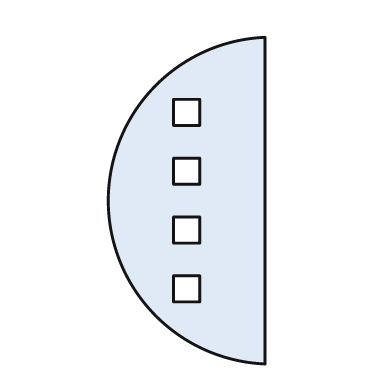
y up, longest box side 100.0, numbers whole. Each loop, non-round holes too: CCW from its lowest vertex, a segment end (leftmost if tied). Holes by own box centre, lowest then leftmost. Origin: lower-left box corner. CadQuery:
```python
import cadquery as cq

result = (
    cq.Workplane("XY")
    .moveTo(48.0, 0.0)
    .lineTo(48.0, 100.0)
    .threePointArc((0.0, 50.0), (48.0, 0.0))
    .close()
    .moveTo(20.0, 19.0)
    .lineTo(28.0, 19.0)
    .lineTo(28.0, 27.0)
    .lineTo(20.0, 27.0)
    .close()
    .moveTo(20.0, 37.0)
    .lineTo(28.0, 37.0)
    .lineTo(28.0, 45.0)
    .lineTo(20.0, 45.0)
    .close()
    .moveTo(20.0, 55.0)
    .lineTo(28.0, 55.0)
    .lineTo(28.0, 63.0)
    .lineTo(20.0, 63.0)
    .close()
    .moveTo(20.0, 73.0)
    .lineTo(28.0, 73.0)
    .lineTo(28.0, 81.0)
    .lineTo(20.0, 81.0)
    .close()
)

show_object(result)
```